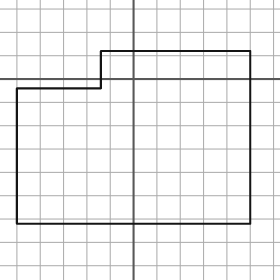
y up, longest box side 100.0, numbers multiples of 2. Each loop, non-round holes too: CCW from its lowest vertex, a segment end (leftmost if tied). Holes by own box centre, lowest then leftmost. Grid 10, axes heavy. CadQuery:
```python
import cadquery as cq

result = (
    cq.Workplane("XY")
    .moveTo(-50.0, -62.0)
    .lineTo(50.0, -62.0)
    .lineTo(50.0, 12.0)
    .lineTo(-14.0, 12.0)
    .lineTo(-14.0, -4.0)
    .lineTo(-50.0, -4.0)
    .close()
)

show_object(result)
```